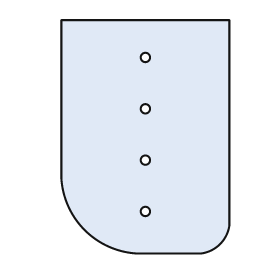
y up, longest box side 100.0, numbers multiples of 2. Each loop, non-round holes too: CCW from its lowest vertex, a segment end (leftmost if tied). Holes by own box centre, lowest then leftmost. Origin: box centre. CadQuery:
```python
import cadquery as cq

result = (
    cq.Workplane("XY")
    .moveTo(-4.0, -50.0)
    .lineTo(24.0, -50.0)
    .threePointArc((32.0, -46.0), (36.0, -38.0))
    .lineTo(36.0, 50.0)
    .lineTo(-36.0, 50.0)
    .lineTo(-36.0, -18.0)
    .threePointArc((-26.0, -40.0), (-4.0, -50.0))
    .close()
    .moveTo(0.0, -32.0)
    .circle(2.0)
    .moveTo(0.0, -10.0)
    .circle(2.0)
    .moveTo(0.0, 12.0)
    .circle(2.0)
    .moveTo(0.0, 34.0)
    .circle(2.0)
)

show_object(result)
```